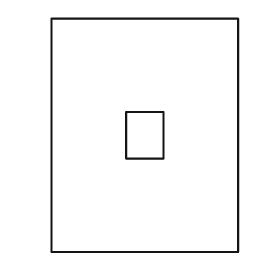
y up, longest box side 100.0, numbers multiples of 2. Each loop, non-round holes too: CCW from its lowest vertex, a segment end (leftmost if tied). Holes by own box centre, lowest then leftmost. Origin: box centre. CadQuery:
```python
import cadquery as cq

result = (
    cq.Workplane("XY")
    .moveTo(-40.0, -50.0)
    .lineTo(40.0, -50.0)
    .lineTo(40.0, 50.0)
    .lineTo(-40.0, 50.0)
    .close()
    .moveTo(-8.0, -10.0)
    .lineTo(8.0, -10.0)
    .lineTo(8.0, 10.0)
    .lineTo(-8.0, 10.0)
    .close()
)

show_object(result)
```